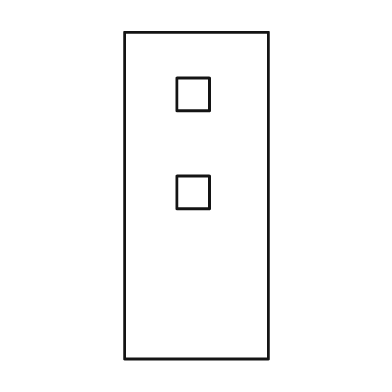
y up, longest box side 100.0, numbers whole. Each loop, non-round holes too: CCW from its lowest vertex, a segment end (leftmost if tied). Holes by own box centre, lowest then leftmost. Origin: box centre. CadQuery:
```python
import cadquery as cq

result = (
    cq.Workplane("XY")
    .moveTo(-22.0, -50.0)
    .lineTo(22.0, -50.0)
    .lineTo(22.0, 50.0)
    .lineTo(-22.0, 50.0)
    .close()
    .moveTo(-6.0, -4.0)
    .lineTo(4.0, -4.0)
    .lineTo(4.0, 6.0)
    .lineTo(-6.0, 6.0)
    .close()
    .moveTo(-6.0, 26.0)
    .lineTo(4.0, 26.0)
    .lineTo(4.0, 36.0)
    .lineTo(-6.0, 36.0)
    .close()
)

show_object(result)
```